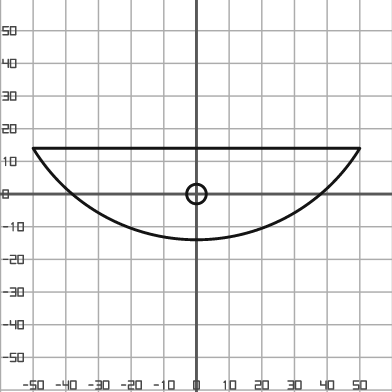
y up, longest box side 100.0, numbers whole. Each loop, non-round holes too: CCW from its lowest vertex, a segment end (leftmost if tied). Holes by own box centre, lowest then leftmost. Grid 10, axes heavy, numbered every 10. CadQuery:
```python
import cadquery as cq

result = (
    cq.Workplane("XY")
    .moveTo(-50.0, 14.0)
    .threePointArc((0.0, -14.0), (50.0, 14.0))
    .close()
    .moveTo(0.0, 0.0)
    .circle(3.0)
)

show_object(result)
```